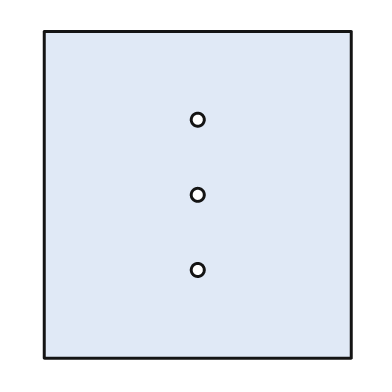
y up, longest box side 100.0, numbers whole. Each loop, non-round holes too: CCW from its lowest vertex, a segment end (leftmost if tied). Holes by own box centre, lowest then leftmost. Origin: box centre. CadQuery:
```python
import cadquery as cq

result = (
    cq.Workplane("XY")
    .moveTo(-47.0, -50.0)
    .lineTo(47.0, -50.0)
    .lineTo(47.0, 50.0)
    .lineTo(-47.0, 50.0)
    .close()
    .moveTo(0.0, -23.0)
    .circle(2.0)
    .moveTo(0.0, 0.0)
    .circle(2.0)
    .moveTo(0.0, 23.0)
    .circle(2.0)
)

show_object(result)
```